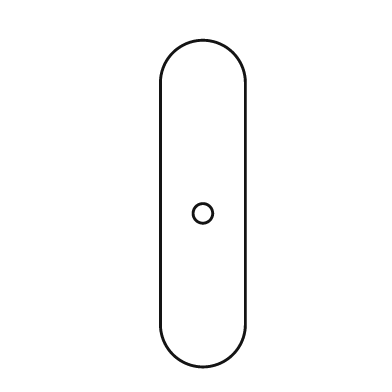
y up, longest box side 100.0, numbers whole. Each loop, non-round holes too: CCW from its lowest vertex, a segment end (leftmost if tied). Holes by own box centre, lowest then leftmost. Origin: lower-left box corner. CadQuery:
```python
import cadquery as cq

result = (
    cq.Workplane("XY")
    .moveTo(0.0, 13.0)
    .threePointArc((13.0, 0.0), (26.0, 13.0))
    .lineTo(26.0, 87.0)
    .threePointArc((13.0, 100.0), (0.0, 87.0))
    .close()
    .moveTo(13.0, 47.0)
    .circle(3.0)
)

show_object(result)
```